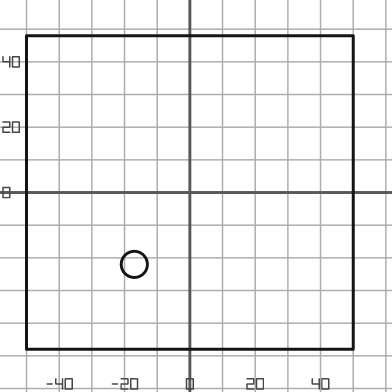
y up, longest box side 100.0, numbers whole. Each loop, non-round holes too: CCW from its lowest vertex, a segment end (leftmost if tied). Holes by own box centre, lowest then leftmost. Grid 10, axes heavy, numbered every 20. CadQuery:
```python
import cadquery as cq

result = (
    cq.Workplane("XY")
    .moveTo(-50.0, -48.0)
    .lineTo(50.0, -48.0)
    .lineTo(50.0, 48.0)
    .lineTo(-50.0, 48.0)
    .close()
    .moveTo(-17.0, -22.0)
    .circle(4.0)
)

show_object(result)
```